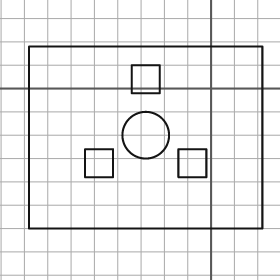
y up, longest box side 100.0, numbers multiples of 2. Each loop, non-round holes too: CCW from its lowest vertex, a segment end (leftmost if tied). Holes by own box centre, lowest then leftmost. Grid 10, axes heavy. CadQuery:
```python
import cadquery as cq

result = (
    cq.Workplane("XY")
    .moveTo(-78.0, -60.0)
    .lineTo(22.0, -60.0)
    .lineTo(22.0, 18.0)
    .lineTo(-78.0, 18.0)
    .close()
    .moveTo(-54.0, -38.0)
    .lineTo(-42.0, -38.0)
    .lineTo(-42.0, -26.0)
    .lineTo(-54.0, -26.0)
    .close()
    .moveTo(-14.0, -38.0)
    .lineTo(-2.0, -38.0)
    .lineTo(-2.0, -26.0)
    .lineTo(-14.0, -26.0)
    .close()
    .moveTo(-28.0, -20.0)
    .circle(10.0)
    .moveTo(-34.0, -2.0)
    .lineTo(-22.0, -2.0)
    .lineTo(-22.0, 10.0)
    .lineTo(-34.0, 10.0)
    .close()
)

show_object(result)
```